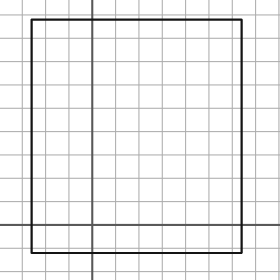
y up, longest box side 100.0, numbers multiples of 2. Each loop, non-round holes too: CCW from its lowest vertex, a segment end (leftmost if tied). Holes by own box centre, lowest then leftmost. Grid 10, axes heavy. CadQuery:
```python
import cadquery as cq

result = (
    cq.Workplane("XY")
    .moveTo(-26.0, -12.0)
    .lineTo(64.0, -12.0)
    .lineTo(64.0, 88.0)
    .lineTo(-26.0, 88.0)
    .close()
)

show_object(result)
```